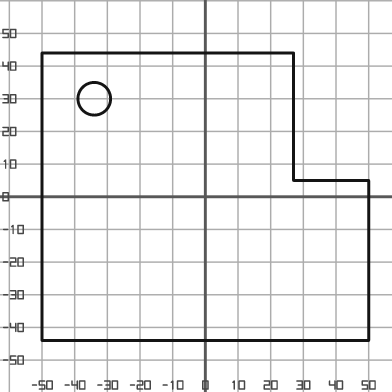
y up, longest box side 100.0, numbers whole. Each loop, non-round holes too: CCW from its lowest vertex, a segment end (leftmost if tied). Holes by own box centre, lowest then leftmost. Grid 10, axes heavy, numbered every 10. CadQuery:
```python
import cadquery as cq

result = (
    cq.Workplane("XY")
    .moveTo(-50.0, -44.0)
    .lineTo(50.0, -44.0)
    .lineTo(50.0, 5.0)
    .lineTo(27.0, 5.0)
    .lineTo(27.0, 44.0)
    .lineTo(-50.0, 44.0)
    .close()
    .moveTo(-34.0, 30.0)
    .circle(5.0)
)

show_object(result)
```